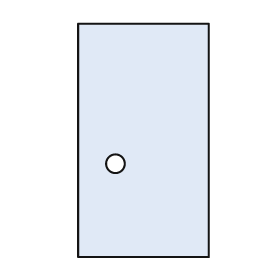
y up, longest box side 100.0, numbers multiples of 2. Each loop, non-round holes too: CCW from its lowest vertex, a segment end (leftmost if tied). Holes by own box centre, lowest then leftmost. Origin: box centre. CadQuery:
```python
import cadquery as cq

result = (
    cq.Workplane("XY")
    .moveTo(-28.0, -50.0)
    .lineTo(28.0, -50.0)
    .lineTo(28.0, 50.0)
    .lineTo(-28.0, 50.0)
    .close()
    .moveTo(-12.0, -10.0)
    .circle(4.0)
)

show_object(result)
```